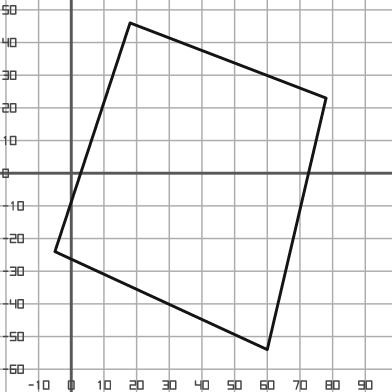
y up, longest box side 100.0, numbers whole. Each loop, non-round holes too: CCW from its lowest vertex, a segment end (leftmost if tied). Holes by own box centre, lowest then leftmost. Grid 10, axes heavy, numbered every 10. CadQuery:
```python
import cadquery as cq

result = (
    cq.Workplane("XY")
    .moveTo(60.0, -54.0)
    .lineTo(78.0, 23.0)
    .lineTo(18.0, 46.0)
    .lineTo(-5.0, -24.0)
    .close()
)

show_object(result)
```